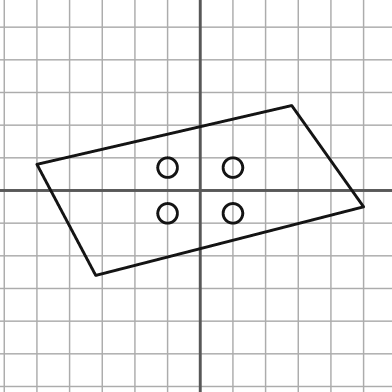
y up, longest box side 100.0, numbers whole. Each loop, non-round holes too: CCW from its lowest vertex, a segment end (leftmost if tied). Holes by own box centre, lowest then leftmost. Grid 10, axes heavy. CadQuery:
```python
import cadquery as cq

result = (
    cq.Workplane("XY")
    .moveTo(-32.0, -26.0)
    .lineTo(50.0, -5.0)
    .lineTo(28.0, 26.0)
    .lineTo(-50.0, 8.0)
    .close()
    .moveTo(-10.0, -7.0)
    .circle(3.0)
    .moveTo(10.0, -7.0)
    .circle(3.0)
    .moveTo(-10.0, 7.0)
    .circle(3.0)
    .moveTo(10.0, 7.0)
    .circle(3.0)
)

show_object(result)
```